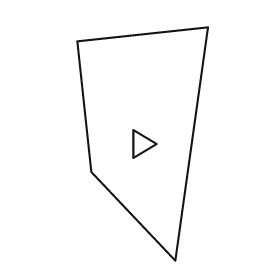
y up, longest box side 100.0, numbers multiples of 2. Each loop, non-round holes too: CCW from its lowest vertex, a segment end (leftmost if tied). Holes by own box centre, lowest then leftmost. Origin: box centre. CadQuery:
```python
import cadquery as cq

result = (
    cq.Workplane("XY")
    .moveTo(14.0, -50.0)
    .lineTo(28.0, 50.0)
    .lineTo(-28.0, 44.0)
    .lineTo(-22.0, -12.0)
    .close()
    .moveTo(-4.0, -6.0)
    .lineTo(6.0, 0.0)
    .lineTo(-4.0, 6.0)
    .close()
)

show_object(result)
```